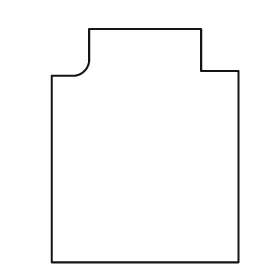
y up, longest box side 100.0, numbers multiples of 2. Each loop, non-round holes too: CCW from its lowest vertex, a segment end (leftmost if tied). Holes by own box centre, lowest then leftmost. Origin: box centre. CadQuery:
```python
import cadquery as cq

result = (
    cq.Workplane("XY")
    .moveTo(-40.0, -50.0)
    .lineTo(40.0, -50.0)
    .lineTo(40.0, 32.0)
    .lineTo(24.0, 32.0)
    .lineTo(24.0, 50.0)
    .lineTo(-24.0, 50.0)
    .lineTo(-24.0, 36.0)
    .threePointArc((-26.0, 32.0), (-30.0, 30.0))
    .lineTo(-40.0, 30.0)
    .close()
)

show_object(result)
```